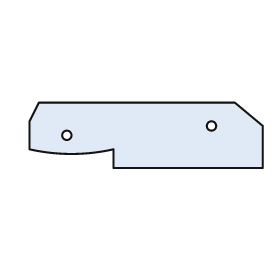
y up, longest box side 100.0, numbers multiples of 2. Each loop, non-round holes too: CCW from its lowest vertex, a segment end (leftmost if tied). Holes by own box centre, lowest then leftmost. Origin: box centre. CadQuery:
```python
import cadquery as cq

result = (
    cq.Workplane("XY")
    .moveTo(-14.0, -14.0)
    .lineTo(50.0, -14.0)
    .lineTo(50.0, 4.0)
    .lineTo(38.0, 14.0)
    .lineTo(-46.0, 14.0)
    .lineTo(-50.0, 6.0)
    .lineTo(-50.0, -6.0)
    .threePointArc((-32.0, -8.0), (-14.0, -6.0))
    .close()
    .moveTo(-34.0, 0.0)
    .circle(2.0)
    .moveTo(28.0, 4.0)
    .circle(2.0)
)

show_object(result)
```